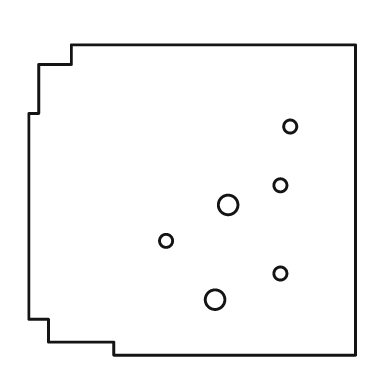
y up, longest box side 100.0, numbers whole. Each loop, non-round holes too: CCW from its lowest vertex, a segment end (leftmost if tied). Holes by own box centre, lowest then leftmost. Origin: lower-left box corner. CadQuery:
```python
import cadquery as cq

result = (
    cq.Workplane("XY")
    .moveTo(26.0, 0.0)
    .lineTo(100.0, 0.0)
    .lineTo(100.0, 95.0)
    .lineTo(13.0, 95.0)
    .lineTo(13.0, 89.0)
    .lineTo(3.0, 89.0)
    .lineTo(3.0, 74.0)
    .lineTo(0.0, 74.0)
    .lineTo(0.0, 11.0)
    .lineTo(6.0, 11.0)
    .lineTo(6.0, 4.0)
    .lineTo(26.0, 4.0)
    .close()
    .moveTo(57.0, 17.0)
    .circle(3.0)
    .moveTo(77.0, 25.0)
    .circle(2.0)
    .moveTo(42.0, 35.0)
    .circle(2.0)
    .moveTo(61.0, 46.0)
    .circle(3.0)
    .moveTo(77.0, 52.0)
    .circle(2.0)
    .moveTo(80.0, 70.0)
    .circle(2.0)
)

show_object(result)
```